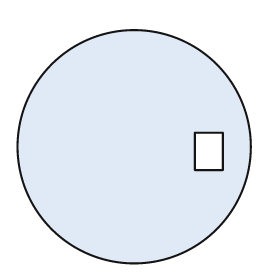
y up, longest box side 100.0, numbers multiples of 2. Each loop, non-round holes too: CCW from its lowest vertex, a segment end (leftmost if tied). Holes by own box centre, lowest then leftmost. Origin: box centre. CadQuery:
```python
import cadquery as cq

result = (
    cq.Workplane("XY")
    .moveTo(0.0, 0.0)
    .circle(50.0)
    .moveTo(26.0, -10.0)
    .lineTo(38.0, -10.0)
    .lineTo(38.0, 6.0)
    .lineTo(26.0, 6.0)
    .close()
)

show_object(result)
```